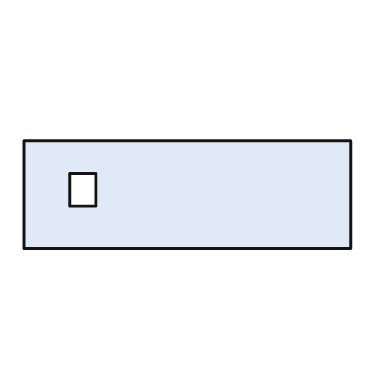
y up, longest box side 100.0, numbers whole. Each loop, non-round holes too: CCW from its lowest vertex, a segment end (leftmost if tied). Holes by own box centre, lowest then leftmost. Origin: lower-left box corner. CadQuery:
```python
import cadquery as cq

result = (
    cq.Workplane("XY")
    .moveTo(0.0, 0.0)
    .lineTo(100.0, 0.0)
    .lineTo(100.0, 33.0)
    .lineTo(0.0, 33.0)
    .close()
    .moveTo(14.0, 13.0)
    .lineTo(22.0, 13.0)
    .lineTo(22.0, 23.0)
    .lineTo(14.0, 23.0)
    .close()
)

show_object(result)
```